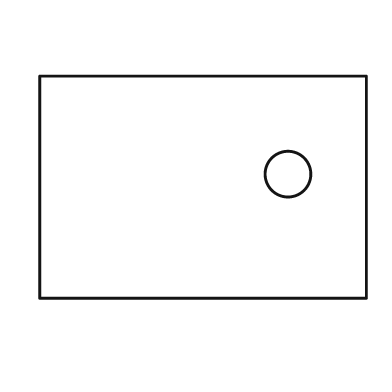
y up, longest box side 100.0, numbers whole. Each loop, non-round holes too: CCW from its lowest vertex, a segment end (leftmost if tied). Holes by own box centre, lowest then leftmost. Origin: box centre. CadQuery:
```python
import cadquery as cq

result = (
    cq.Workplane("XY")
    .moveTo(-50.0, -34.0)
    .lineTo(50.0, -34.0)
    .lineTo(50.0, 34.0)
    .lineTo(-50.0, 34.0)
    .close()
    .moveTo(26.0, 4.0)
    .circle(7.0)
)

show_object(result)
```